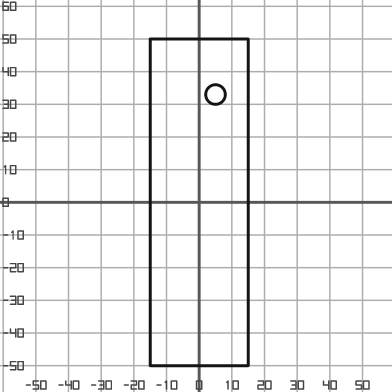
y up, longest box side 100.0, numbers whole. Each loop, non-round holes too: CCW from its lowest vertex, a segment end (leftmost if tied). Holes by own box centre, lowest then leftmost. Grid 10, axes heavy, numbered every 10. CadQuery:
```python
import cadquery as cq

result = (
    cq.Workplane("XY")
    .moveTo(-15.0, -50.0)
    .lineTo(15.0, -50.0)
    .lineTo(15.0, 50.0)
    .lineTo(-15.0, 50.0)
    .close()
    .moveTo(5.0, 33.0)
    .circle(3.0)
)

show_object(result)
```